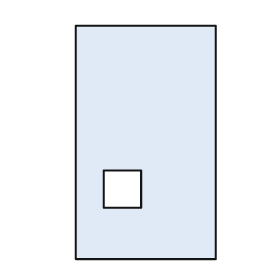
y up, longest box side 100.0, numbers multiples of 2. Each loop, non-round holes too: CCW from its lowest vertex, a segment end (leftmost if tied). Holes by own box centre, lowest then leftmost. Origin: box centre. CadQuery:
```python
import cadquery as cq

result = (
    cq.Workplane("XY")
    .moveTo(-30.0, -50.0)
    .lineTo(30.0, -50.0)
    .lineTo(30.0, 50.0)
    .lineTo(-30.0, 50.0)
    .close()
    .moveTo(-18.0, -28.0)
    .lineTo(-2.0, -28.0)
    .lineTo(-2.0, -12.0)
    .lineTo(-18.0, -12.0)
    .close()
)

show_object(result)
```